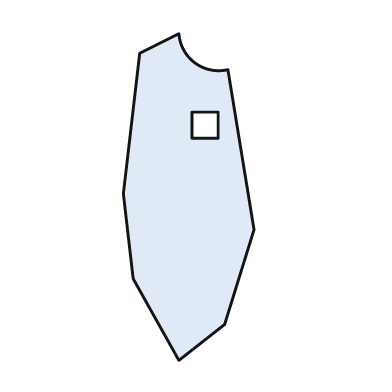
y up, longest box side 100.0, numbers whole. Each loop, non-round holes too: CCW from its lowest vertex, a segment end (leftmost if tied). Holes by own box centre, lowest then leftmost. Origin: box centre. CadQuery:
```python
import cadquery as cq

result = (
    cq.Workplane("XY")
    .moveTo(-3.0, -50.0)
    .lineTo(11.0, -39.0)
    .lineTo(20.0, -10.0)
    .lineTo(12.0, 39.0)
    .threePointArc((2.0, 41.0), (-3.0, 50.0))
    .lineTo(-15.0, 44.0)
    .lineTo(-20.0, 1.0)
    .lineTo(-17.0, -25.0)
    .close()
    .moveTo(1.0, 18.0)
    .lineTo(9.0, 18.0)
    .lineTo(9.0, 26.0)
    .lineTo(1.0, 26.0)
    .close()
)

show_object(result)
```